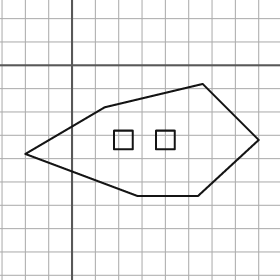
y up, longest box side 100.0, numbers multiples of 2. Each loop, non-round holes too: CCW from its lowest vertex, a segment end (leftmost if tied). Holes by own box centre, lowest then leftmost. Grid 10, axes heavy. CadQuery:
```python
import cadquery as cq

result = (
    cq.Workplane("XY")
    .moveTo(28.0, -56.0)
    .lineTo(54.0, -56.0)
    .lineTo(80.0, -32.0)
    .lineTo(56.0, -8.0)
    .lineTo(14.0, -18.0)
    .lineTo(-20.0, -38.0)
    .close()
    .moveTo(18.0, -36.0)
    .lineTo(26.0, -36.0)
    .lineTo(26.0, -28.0)
    .lineTo(18.0, -28.0)
    .close()
    .moveTo(36.0, -36.0)
    .lineTo(44.0, -36.0)
    .lineTo(44.0, -28.0)
    .lineTo(36.0, -28.0)
    .close()
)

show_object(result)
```